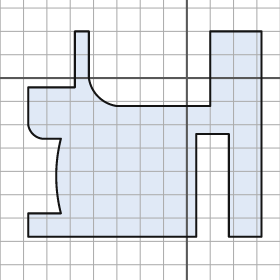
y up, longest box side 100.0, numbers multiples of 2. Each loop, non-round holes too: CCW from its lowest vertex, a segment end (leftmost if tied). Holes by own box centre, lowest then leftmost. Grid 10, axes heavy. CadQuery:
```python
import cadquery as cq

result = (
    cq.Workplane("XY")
    .moveTo(-68.0, -68.0)
    .lineTo(4.0, -68.0)
    .lineTo(4.0, -24.0)
    .lineTo(18.0, -24.0)
    .lineTo(18.0, -68.0)
    .lineTo(32.0, -68.0)
    .lineTo(32.0, 20.0)
    .lineTo(10.0, 20.0)
    .lineTo(10.0, -12.0)
    .lineTo(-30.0, -12.0)
    .threePointArc((-38.0, -8.0), (-42.0, 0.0))
    .lineTo(-42.0, 20.0)
    .lineTo(-48.0, 20.0)
    .lineTo(-48.0, -4.0)
    .lineTo(-68.0, -4.0)
    .lineTo(-68.0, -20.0)
    .threePointArc((-66.0, -24.0), (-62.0, -26.0))
    .lineTo(-54.0, -26.0)
    .threePointArc((-56.0, -42.0), (-54.0, -58.0))
    .lineTo(-68.0, -58.0)
    .close()
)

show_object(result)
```